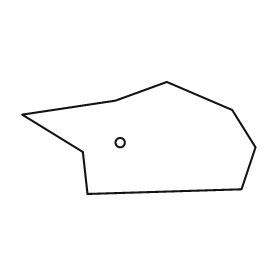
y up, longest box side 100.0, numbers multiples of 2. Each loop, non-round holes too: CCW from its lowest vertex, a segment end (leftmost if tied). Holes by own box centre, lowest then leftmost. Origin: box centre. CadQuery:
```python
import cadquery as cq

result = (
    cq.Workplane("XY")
    .moveTo(-22.0, -24.0)
    .lineTo(44.0, -22.0)
    .lineTo(50.0, -4.0)
    .lineTo(40.0, 12.0)
    .lineTo(12.0, 24.0)
    .lineTo(-10.0, 16.0)
    .lineTo(-50.0, 10.0)
    .lineTo(-24.0, -6.0)
    .close()
    .moveTo(-8.0, -2.0)
    .circle(2.0)
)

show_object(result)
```